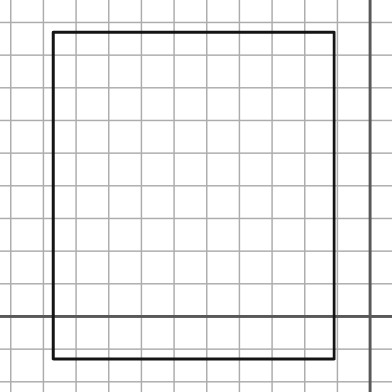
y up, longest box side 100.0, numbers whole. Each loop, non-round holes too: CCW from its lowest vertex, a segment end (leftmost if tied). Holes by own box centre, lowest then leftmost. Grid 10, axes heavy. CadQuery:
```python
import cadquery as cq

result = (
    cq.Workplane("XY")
    .moveTo(-97.0, -13.0)
    .lineTo(-11.0, -13.0)
    .lineTo(-11.0, 87.0)
    .lineTo(-97.0, 87.0)
    .close()
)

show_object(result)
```